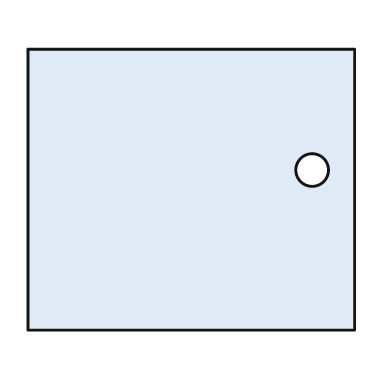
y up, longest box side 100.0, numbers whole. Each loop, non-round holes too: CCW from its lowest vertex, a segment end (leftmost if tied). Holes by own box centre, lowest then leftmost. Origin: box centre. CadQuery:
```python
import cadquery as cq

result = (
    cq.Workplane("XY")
    .moveTo(-50.0, -43.0)
    .lineTo(50.0, -43.0)
    .lineTo(50.0, 43.0)
    .lineTo(-50.0, 43.0)
    .close()
    .moveTo(37.0, 6.0)
    .circle(5.0)
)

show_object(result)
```